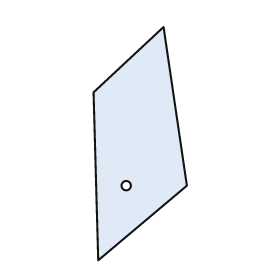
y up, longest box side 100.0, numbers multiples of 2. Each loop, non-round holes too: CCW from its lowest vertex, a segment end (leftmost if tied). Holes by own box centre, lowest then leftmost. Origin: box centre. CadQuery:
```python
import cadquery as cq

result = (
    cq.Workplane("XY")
    .moveTo(-18.0, -50.0)
    .lineTo(20.0, -18.0)
    .lineTo(10.0, 50.0)
    .lineTo(-20.0, 22.0)
    .close()
    .moveTo(-6.0, -18.0)
    .circle(2.0)
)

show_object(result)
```